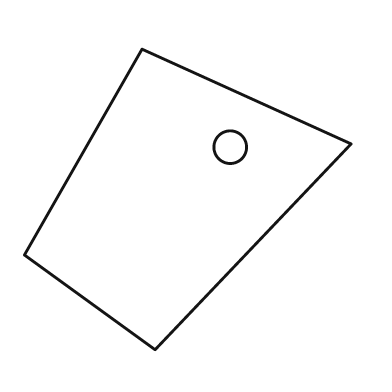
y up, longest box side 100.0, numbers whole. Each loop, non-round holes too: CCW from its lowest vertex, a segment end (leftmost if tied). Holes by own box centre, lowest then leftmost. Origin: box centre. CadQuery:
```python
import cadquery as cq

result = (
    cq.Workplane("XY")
    .moveTo(-10.0, -46.0)
    .lineTo(50.0, 17.0)
    .lineTo(-14.0, 46.0)
    .lineTo(-50.0, -17.0)
    .close()
    .moveTo(13.0, 16.0)
    .circle(5.0)
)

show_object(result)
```